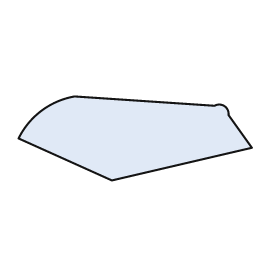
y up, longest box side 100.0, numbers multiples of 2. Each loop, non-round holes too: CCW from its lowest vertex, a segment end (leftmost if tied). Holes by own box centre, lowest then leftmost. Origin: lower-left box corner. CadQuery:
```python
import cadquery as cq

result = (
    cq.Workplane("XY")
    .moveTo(40.0, 0.0)
    .lineTo(100.0, 14.0)
    .lineTo(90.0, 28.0)
    .threePointArc((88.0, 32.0), (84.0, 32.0))
    .lineTo(24.0, 36.0)
    .threePointArc((10.0, 30.0), (0.0, 18.0))
    .close()
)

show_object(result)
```